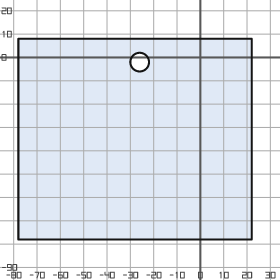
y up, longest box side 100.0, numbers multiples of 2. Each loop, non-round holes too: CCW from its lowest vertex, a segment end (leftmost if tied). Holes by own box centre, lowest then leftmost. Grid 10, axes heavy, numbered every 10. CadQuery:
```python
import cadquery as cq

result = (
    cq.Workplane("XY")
    .moveTo(-78.0, -78.0)
    .lineTo(22.0, -78.0)
    .lineTo(22.0, 8.0)
    .lineTo(-78.0, 8.0)
    .close()
    .moveTo(-26.0, -2.0)
    .circle(4.0)
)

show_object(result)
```